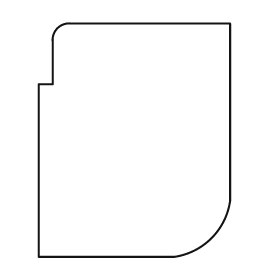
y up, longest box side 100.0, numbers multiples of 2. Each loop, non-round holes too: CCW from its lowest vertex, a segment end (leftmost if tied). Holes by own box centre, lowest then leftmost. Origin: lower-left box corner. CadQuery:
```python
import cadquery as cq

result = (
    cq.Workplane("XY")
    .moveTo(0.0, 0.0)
    .lineTo(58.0, 0.0)
    .threePointArc((74.0, 8.0), (82.0, 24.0))
    .lineTo(82.0, 100.0)
    .lineTo(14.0, 100.0)
    .threePointArc((8.0, 98.0), (6.0, 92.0))
    .lineTo(6.0, 74.0)
    .lineTo(0.0, 74.0)
    .close()
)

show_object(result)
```